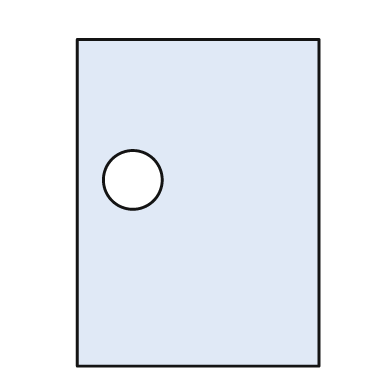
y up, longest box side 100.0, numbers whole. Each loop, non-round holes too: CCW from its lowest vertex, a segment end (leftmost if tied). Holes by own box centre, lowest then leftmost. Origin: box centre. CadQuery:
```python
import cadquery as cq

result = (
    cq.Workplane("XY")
    .moveTo(-37.0, -50.0)
    .lineTo(37.0, -50.0)
    .lineTo(37.0, 50.0)
    .lineTo(-37.0, 50.0)
    .close()
    .moveTo(-20.0, 7.0)
    .circle(9.0)
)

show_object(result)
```